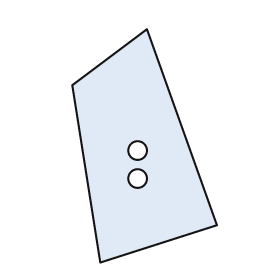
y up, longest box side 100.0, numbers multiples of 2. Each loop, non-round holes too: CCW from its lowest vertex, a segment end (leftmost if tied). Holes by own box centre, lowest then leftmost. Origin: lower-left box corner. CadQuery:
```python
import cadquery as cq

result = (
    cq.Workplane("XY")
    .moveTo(12.0, 0.0)
    .lineTo(62.0, 16.0)
    .lineTo(32.0, 100.0)
    .lineTo(0.0, 76.0)
    .close()
    .moveTo(28.0, 36.0)
    .circle(4.0)
    .moveTo(28.0, 48.0)
    .circle(4.0)
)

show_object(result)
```